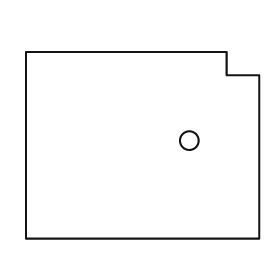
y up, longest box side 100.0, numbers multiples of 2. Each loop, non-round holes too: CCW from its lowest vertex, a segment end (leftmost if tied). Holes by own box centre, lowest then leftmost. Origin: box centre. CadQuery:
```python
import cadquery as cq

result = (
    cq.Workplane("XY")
    .moveTo(-50.0, -40.0)
    .lineTo(50.0, -40.0)
    .lineTo(50.0, 30.0)
    .lineTo(36.0, 30.0)
    .lineTo(36.0, 40.0)
    .lineTo(-50.0, 40.0)
    .close()
    .moveTo(20.0, 2.0)
    .circle(4.0)
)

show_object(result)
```